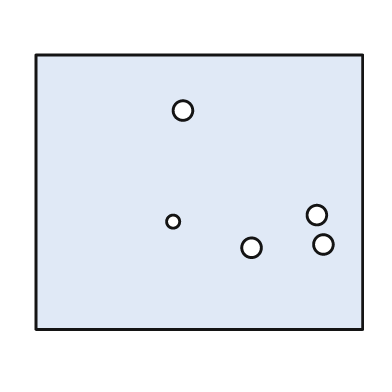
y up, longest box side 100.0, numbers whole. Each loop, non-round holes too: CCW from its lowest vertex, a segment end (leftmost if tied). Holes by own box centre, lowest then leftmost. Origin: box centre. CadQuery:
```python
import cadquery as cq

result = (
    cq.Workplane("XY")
    .moveTo(-50.0, -42.0)
    .lineTo(50.0, -42.0)
    .lineTo(50.0, 42.0)
    .lineTo(-50.0, 42.0)
    .close()
    .moveTo(16.0, -17.0)
    .circle(3.0)
    .moveTo(38.0, -16.0)
    .circle(3.0)
    .moveTo(-8.0, -9.0)
    .circle(2.0)
    .moveTo(36.0, -7.0)
    .circle(3.0)
    .moveTo(-5.0, 25.0)
    .circle(3.0)
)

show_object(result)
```